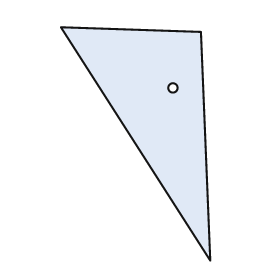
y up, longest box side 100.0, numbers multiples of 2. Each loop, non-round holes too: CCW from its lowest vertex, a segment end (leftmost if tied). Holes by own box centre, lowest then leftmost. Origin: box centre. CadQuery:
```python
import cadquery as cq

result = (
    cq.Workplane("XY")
    .moveTo(32.0, -50.0)
    .lineTo(28.0, 48.0)
    .lineTo(-32.0, 50.0)
    .close()
    .moveTo(16.0, 24.0)
    .circle(2.0)
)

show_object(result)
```